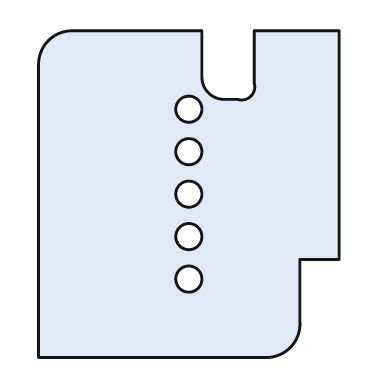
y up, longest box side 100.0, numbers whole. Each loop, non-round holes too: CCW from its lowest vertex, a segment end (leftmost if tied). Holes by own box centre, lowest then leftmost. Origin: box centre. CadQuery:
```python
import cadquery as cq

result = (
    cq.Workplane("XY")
    .moveTo(-46.0, -50.0)
    .lineTo(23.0, -50.0)
    .threePointArc((31.0, -47.0), (34.0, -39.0))
    .lineTo(34.0, -20.0)
    .lineTo(46.0, -20.0)
    .lineTo(46.0, 50.0)
    .lineTo(20.0, 50.0)
    .lineTo(20.0, 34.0)
    .threePointArc((19.0, 30.0), (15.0, 29.0))
    .lineTo(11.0, 29.0)
    .threePointArc((6.0, 31.0), (4.0, 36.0))
    .lineTo(4.0, 50.0)
    .lineTo(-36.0, 50.0)
    .threePointArc((-43.0, 47.0), (-46.0, 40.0))
    .close()
    .moveTo(0.0, -26.0)
    .circle(4.0)
    .moveTo(0.0, -13.0)
    .circle(4.0)
    .moveTo(0.0, 0.0)
    .circle(4.0)
    .moveTo(0.0, 13.0)
    .circle(4.0)
    .moveTo(0.0, 26.0)
    .circle(4.0)
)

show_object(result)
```